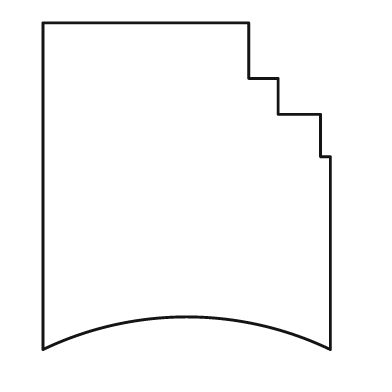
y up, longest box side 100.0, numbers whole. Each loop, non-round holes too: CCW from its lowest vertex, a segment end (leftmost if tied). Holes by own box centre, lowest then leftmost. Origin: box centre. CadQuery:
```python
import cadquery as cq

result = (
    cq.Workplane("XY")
    .moveTo(-44.0, -50.0)
    .threePointArc((0.0, -40.0), (44.0, -50.0))
    .lineTo(44.0, 9.0)
    .lineTo(41.0, 9.0)
    .lineTo(41.0, 22.0)
    .lineTo(28.0, 22.0)
    .lineTo(28.0, 33.0)
    .lineTo(19.0, 33.0)
    .lineTo(19.0, 50.0)
    .lineTo(-44.0, 50.0)
    .close()
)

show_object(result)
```